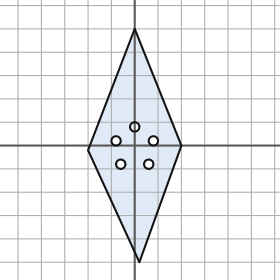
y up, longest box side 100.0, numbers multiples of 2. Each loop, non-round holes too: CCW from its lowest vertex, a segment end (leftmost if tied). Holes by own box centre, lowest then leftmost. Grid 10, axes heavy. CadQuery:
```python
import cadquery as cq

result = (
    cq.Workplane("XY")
    .moveTo(2.0, -50.0)
    .lineTo(20.0, 0.0)
    .lineTo(0.0, 50.0)
    .lineTo(-20.0, -2.0)
    .close()
    .moveTo(-6.0, -8.0)
    .circle(2.0)
    .moveTo(6.0, -8.0)
    .circle(2.0)
    .moveTo(-8.0, 2.0)
    .circle(2.0)
    .moveTo(8.0, 2.0)
    .circle(2.0)
    .moveTo(0.0, 8.0)
    .circle(2.0)
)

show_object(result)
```